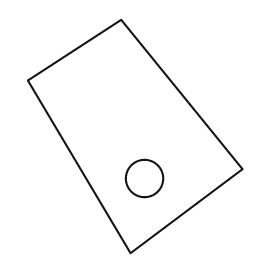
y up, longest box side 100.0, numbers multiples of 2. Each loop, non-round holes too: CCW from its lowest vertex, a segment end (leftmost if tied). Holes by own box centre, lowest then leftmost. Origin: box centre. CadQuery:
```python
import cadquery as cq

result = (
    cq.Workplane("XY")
    .moveTo(-2.0, -50.0)
    .lineTo(46.0, -14.0)
    .lineTo(-6.0, 50.0)
    .lineTo(-46.0, 24.0)
    .close()
    .moveTo(4.0, -18.0)
    .circle(8.0)
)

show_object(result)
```